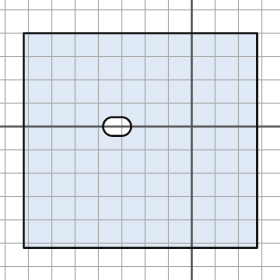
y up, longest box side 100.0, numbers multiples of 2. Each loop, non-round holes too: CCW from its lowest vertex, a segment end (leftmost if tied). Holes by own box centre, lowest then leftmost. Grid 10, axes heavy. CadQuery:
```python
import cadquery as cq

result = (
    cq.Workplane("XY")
    .moveTo(-72.0, -52.0)
    .lineTo(28.0, -52.0)
    .lineTo(28.0, 40.0)
    .lineTo(-72.0, 40.0)
    .close()
    .moveTo(-34.0, -4.0)
    .lineTo(-30.0, -4.0)
    .threePointArc((-26.0, 0.0), (-30.0, 4.0))
    .lineTo(-34.0, 4.0)
    .threePointArc((-38.0, 0.0), (-34.0, -4.0))
    .close()
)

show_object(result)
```